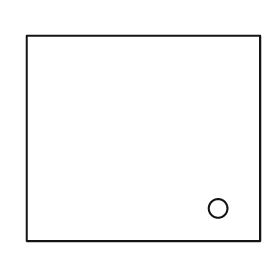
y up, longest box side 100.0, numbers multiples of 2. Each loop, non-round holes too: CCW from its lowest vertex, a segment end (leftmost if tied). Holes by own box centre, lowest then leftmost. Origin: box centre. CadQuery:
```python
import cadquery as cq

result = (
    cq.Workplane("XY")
    .moveTo(-50.0, -44.0)
    .lineTo(50.0, -44.0)
    .lineTo(50.0, 44.0)
    .lineTo(-50.0, 44.0)
    .close()
    .moveTo(32.0, -30.0)
    .circle(4.0)
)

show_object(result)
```